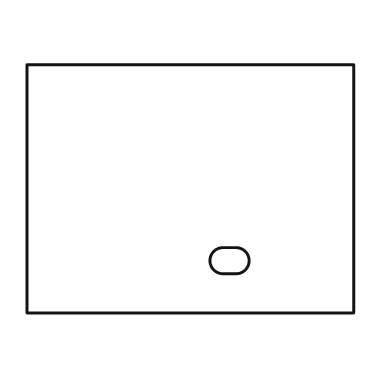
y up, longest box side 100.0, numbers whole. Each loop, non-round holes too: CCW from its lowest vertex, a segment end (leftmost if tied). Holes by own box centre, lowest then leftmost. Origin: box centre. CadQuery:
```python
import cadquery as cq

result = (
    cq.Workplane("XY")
    .moveTo(-50.0, -38.0)
    .lineTo(50.0, -38.0)
    .lineTo(50.0, 38.0)
    .lineTo(-50.0, 38.0)
    .close()
    .moveTo(10.0, -26.0)
    .lineTo(14.0, -26.0)
    .threePointArc((18.0, -22.0), (14.0, -18.0))
    .lineTo(10.0, -18.0)
    .threePointArc((6.0, -22.0), (10.0, -26.0))
    .close()
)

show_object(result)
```